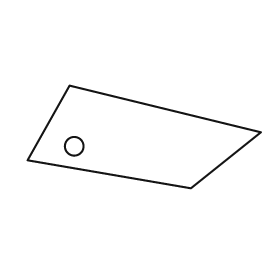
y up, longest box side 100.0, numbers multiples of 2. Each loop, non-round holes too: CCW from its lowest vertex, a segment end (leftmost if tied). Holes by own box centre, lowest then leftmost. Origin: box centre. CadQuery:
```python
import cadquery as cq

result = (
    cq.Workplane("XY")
    .moveTo(20.0, -22.0)
    .lineTo(50.0, 2.0)
    .lineTo(-32.0, 22.0)
    .lineTo(-50.0, -10.0)
    .close()
    .moveTo(-30.0, -4.0)
    .circle(4.0)
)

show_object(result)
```